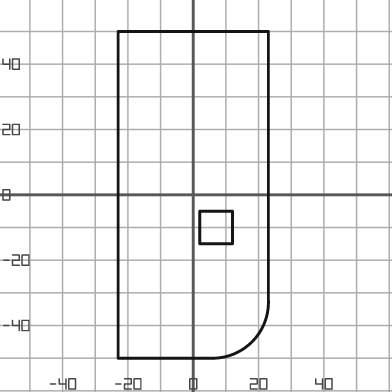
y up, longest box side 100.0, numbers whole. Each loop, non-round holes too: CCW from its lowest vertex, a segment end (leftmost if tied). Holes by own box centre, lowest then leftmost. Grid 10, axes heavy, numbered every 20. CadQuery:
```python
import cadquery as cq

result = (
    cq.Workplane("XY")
    .moveTo(-23.0, -50.0)
    .lineTo(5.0, -50.0)
    .threePointArc((18.0, -45.0), (23.0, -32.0))
    .lineTo(23.0, 50.0)
    .lineTo(-23.0, 50.0)
    .close()
    .moveTo(2.0, -15.0)
    .lineTo(12.0, -15.0)
    .lineTo(12.0, -5.0)
    .lineTo(2.0, -5.0)
    .close()
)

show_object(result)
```